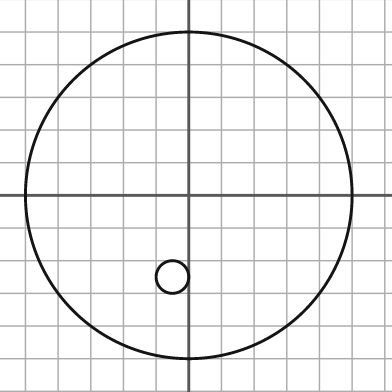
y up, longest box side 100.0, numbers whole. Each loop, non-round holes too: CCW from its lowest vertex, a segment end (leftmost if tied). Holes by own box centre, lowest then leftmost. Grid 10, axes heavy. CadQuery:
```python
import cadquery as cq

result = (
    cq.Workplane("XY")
    .moveTo(0.0, 0.0)
    .circle(50.0)
    .moveTo(-5.0, -25.0)
    .circle(5.0)
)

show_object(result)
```